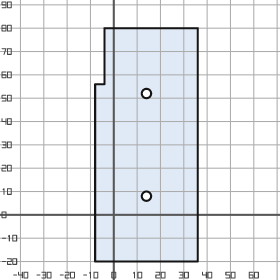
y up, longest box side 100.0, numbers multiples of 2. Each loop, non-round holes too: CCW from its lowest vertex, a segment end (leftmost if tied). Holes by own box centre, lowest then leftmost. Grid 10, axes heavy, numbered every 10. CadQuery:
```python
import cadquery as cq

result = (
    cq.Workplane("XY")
    .moveTo(-8.0, -20.0)
    .lineTo(36.0, -20.0)
    .lineTo(36.0, 80.0)
    .lineTo(-4.0, 80.0)
    .lineTo(-4.0, 56.0)
    .lineTo(-8.0, 56.0)
    .close()
    .moveTo(14.0, 8.0)
    .circle(2.0)
    .moveTo(14.0, 52.0)
    .circle(2.0)
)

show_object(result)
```